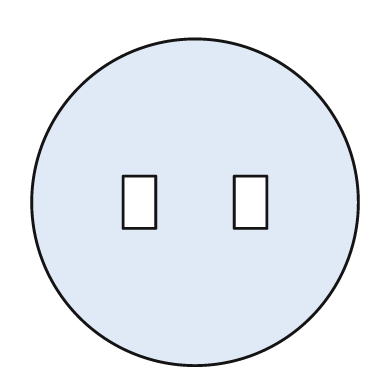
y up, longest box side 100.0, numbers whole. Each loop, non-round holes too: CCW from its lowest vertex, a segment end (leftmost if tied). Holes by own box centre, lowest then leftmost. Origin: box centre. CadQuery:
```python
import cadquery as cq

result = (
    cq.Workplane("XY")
    .moveTo(0.0, 0.0)
    .circle(50.0)
    .moveTo(-22.0, -8.0)
    .lineTo(-12.0, -8.0)
    .lineTo(-12.0, 8.0)
    .lineTo(-22.0, 8.0)
    .close()
    .moveTo(12.0, -8.0)
    .lineTo(22.0, -8.0)
    .lineTo(22.0, 8.0)
    .lineTo(12.0, 8.0)
    .close()
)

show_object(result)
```